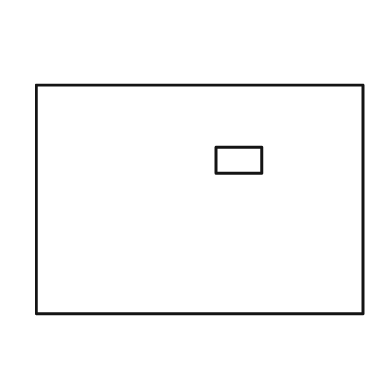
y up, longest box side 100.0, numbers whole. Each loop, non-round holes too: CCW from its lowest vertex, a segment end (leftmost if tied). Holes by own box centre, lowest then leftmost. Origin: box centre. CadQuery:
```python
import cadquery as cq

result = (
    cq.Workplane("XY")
    .moveTo(-50.0, -35.0)
    .lineTo(50.0, -35.0)
    .lineTo(50.0, 35.0)
    .lineTo(-50.0, 35.0)
    .close()
    .moveTo(5.0, 8.0)
    .lineTo(19.0, 8.0)
    .lineTo(19.0, 16.0)
    .lineTo(5.0, 16.0)
    .close()
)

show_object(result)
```